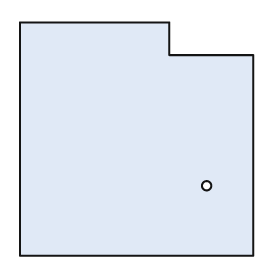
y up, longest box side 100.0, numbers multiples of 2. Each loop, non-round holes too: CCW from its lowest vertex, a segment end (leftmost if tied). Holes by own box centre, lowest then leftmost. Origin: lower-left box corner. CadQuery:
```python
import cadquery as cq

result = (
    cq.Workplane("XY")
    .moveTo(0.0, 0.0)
    .lineTo(100.0, 0.0)
    .lineTo(100.0, 86.0)
    .lineTo(64.0, 86.0)
    .lineTo(64.0, 100.0)
    .lineTo(0.0, 100.0)
    .close()
    .moveTo(80.0, 30.0)
    .circle(2.0)
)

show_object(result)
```